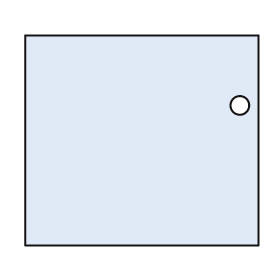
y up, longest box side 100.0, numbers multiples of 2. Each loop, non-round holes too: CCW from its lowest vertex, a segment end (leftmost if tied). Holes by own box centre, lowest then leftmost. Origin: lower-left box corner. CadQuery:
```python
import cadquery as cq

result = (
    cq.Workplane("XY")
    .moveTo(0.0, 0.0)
    .lineTo(100.0, 0.0)
    .lineTo(100.0, 90.0)
    .lineTo(0.0, 90.0)
    .close()
    .moveTo(92.0, 60.0)
    .circle(4.0)
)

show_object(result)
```